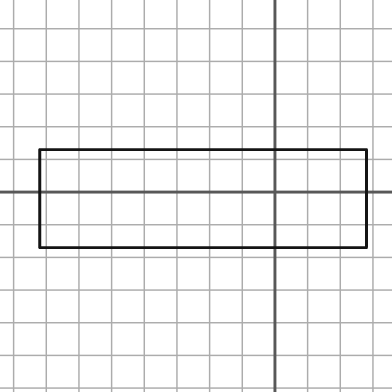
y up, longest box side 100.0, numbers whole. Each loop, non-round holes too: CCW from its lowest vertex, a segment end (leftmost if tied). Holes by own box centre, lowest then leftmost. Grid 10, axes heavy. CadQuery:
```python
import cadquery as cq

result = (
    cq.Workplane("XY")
    .moveTo(-72.0, -17.0)
    .lineTo(28.0, -17.0)
    .lineTo(28.0, 13.0)
    .lineTo(-72.0, 13.0)
    .close()
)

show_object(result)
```